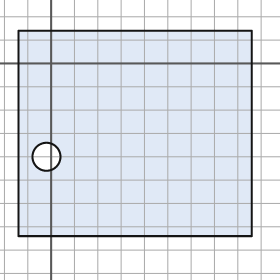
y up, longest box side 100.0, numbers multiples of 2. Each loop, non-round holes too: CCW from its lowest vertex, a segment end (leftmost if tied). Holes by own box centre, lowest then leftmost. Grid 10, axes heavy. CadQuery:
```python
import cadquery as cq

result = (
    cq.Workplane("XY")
    .moveTo(-14.0, -74.0)
    .lineTo(86.0, -74.0)
    .lineTo(86.0, 14.0)
    .lineTo(-14.0, 14.0)
    .close()
    .moveTo(-2.0, -40.0)
    .circle(6.0)
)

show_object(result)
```